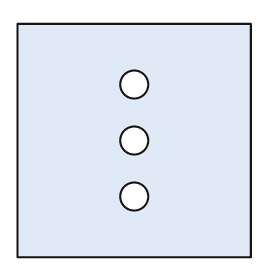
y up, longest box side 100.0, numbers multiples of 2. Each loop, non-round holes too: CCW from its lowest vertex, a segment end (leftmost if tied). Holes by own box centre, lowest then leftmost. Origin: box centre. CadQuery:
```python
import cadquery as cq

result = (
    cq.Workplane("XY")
    .moveTo(-50.0, -50.0)
    .lineTo(50.0, -50.0)
    .lineTo(50.0, 50.0)
    .lineTo(-50.0, 50.0)
    .close()
    .moveTo(0.0, -24.0)
    .circle(6.0)
    .moveTo(0.0, 0.0)
    .circle(6.0)
    .moveTo(0.0, 24.0)
    .circle(6.0)
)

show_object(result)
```